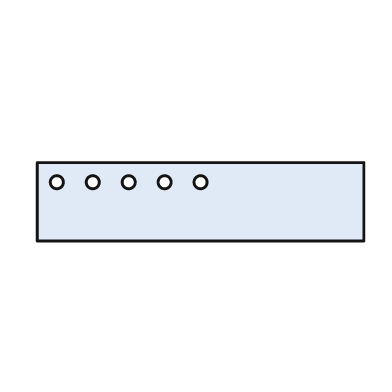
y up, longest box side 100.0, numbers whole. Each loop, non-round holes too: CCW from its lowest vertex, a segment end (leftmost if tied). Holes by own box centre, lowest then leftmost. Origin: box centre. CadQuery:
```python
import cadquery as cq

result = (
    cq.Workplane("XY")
    .moveTo(-50.0, -12.0)
    .lineTo(50.0, -12.0)
    .lineTo(50.0, 12.0)
    .lineTo(-50.0, 12.0)
    .close()
    .moveTo(-44.0, 6.0)
    .circle(2.0)
    .moveTo(-33.0, 6.0)
    .circle(2.0)
    .moveTo(-22.0, 6.0)
    .circle(2.0)
    .moveTo(-11.0, 6.0)
    .circle(2.0)
    .moveTo(0.0, 6.0)
    .circle(2.0)
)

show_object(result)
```